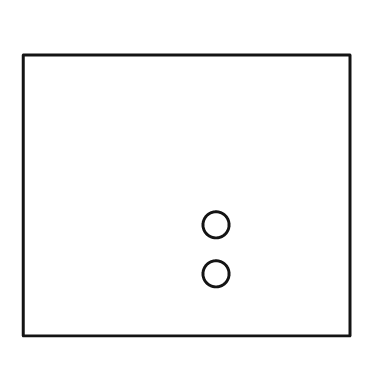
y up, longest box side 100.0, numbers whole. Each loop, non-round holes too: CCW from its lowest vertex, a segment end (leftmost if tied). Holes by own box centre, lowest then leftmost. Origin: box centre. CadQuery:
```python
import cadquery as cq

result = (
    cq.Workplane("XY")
    .moveTo(-50.0, -43.0)
    .lineTo(50.0, -43.0)
    .lineTo(50.0, 43.0)
    .lineTo(-50.0, 43.0)
    .close()
    .moveTo(9.0, -24.0)
    .circle(4.0)
    .moveTo(9.0, -9.0)
    .circle(4.0)
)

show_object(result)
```